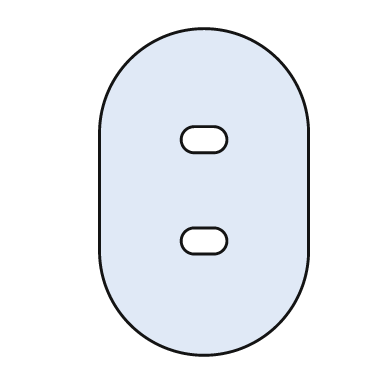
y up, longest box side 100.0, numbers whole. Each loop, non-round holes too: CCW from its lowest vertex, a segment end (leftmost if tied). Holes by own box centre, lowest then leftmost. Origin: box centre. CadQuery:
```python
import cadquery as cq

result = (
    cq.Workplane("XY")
    .moveTo(-32.0, -18.0)
    .threePointArc((0.0, -50.0), (32.0, -18.0))
    .lineTo(32.0, 18.0)
    .threePointArc((0.0, 50.0), (-32.0, 18.0))
    .close()
    .moveTo(-3.0, -19.0)
    .lineTo(3.0, -19.0)
    .threePointArc((7.0, -15.0), (3.0, -11.0))
    .lineTo(-3.0, -11.0)
    .threePointArc((-7.0, -15.0), (-3.0, -19.0))
    .close()
    .moveTo(-3.0, 12.0)
    .lineTo(3.0, 12.0)
    .threePointArc((7.0, 16.0), (3.0, 20.0))
    .lineTo(-3.0, 20.0)
    .threePointArc((-7.0, 16.0), (-3.0, 12.0))
    .close()
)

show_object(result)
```